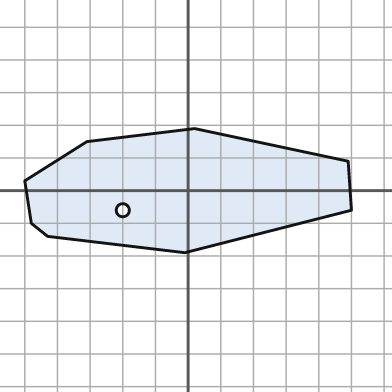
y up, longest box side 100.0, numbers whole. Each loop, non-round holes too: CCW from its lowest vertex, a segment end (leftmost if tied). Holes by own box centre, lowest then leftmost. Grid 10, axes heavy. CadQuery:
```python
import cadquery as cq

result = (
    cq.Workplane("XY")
    .moveTo(-1.0, -19.0)
    .lineTo(50.0, -6.0)
    .lineTo(49.0, 9.0)
    .lineTo(2.0, 19.0)
    .lineTo(-31.0, 15.0)
    .lineTo(-50.0, 3.0)
    .lineTo(-48.0, -10.0)
    .lineTo(-43.0, -14.0)
    .close()
    .moveTo(-20.0, -6.0)
    .circle(2.0)
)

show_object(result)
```